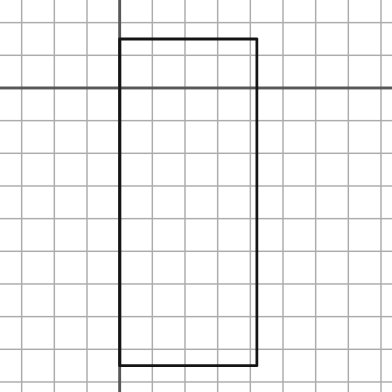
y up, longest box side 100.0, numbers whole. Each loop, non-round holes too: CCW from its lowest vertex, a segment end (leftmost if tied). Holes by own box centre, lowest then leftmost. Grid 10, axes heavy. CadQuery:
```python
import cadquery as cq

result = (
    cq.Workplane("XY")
    .moveTo(0.0, -85.0)
    .lineTo(42.0, -85.0)
    .lineTo(42.0, 15.0)
    .lineTo(0.0, 15.0)
    .close()
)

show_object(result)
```